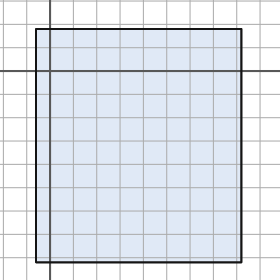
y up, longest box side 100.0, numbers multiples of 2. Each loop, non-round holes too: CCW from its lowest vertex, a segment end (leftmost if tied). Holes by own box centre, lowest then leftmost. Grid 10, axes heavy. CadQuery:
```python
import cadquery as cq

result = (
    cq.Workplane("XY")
    .moveTo(-6.0, -82.0)
    .lineTo(82.0, -82.0)
    .lineTo(82.0, 18.0)
    .lineTo(-6.0, 18.0)
    .close()
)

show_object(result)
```